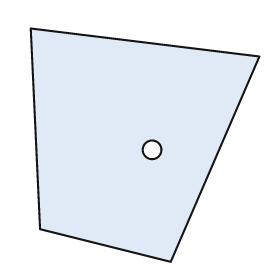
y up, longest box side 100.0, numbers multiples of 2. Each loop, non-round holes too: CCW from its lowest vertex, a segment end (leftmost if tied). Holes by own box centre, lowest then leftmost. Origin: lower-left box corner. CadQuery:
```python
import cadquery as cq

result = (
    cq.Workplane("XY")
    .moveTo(60.0, 0.0)
    .lineTo(98.0, 88.0)
    .lineTo(0.0, 100.0)
    .lineTo(4.0, 14.0)
    .close()
    .moveTo(52.0, 48.0)
    .circle(4.0)
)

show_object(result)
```